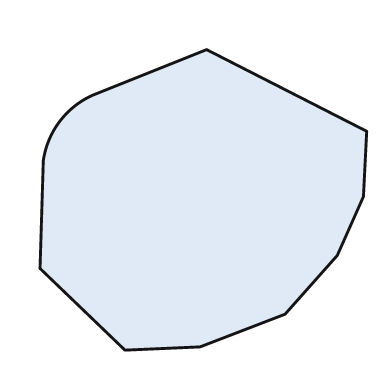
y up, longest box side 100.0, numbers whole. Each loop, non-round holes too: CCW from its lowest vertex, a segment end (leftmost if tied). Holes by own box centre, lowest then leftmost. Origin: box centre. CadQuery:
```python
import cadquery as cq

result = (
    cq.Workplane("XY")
    .moveTo(-24.0, -46.0)
    .lineTo(-1.0, -45.0)
    .lineTo(25.0, -35.0)
    .lineTo(41.0, -17.0)
    .lineTo(49.0, 1.0)
    .lineTo(50.0, 21.0)
    .lineTo(1.0, 46.0)
    .lineTo(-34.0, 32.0)
    .threePointArc((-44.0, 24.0), (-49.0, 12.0))
    .lineTo(-50.0, -21.0)
    .close()
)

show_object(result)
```